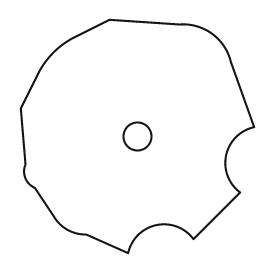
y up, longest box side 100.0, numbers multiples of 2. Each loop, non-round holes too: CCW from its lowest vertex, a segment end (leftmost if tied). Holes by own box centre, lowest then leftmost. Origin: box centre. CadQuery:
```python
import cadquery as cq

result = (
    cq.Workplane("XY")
    .moveTo(-4.0, -50.0)
    .threePointArc((8.0, -38.0), (24.0, -44.0))
    .lineTo(44.0, -24.0)
    .threePointArc((38.0, -8.0), (50.0, 4.0))
    .lineTo(40.0, 32.0)
    .threePointArc((32.0, 44.0), (18.0, 48.0))
    .lineTo(-12.0, 50.0)
    .lineTo(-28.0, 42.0)
    .threePointArc((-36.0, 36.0), (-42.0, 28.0))
    .lineTo(-50.0, 12.0)
    .lineTo(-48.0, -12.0)
    .threePointArc((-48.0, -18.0), (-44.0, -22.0))
    .lineTo(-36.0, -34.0)
    .threePointArc((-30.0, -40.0), (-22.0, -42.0))
    .close()
    .moveTo(0.0, 0.0)
    .circle(6.0)
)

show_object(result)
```